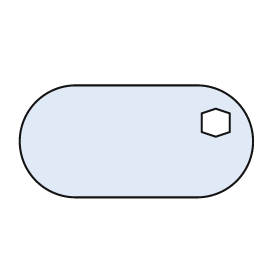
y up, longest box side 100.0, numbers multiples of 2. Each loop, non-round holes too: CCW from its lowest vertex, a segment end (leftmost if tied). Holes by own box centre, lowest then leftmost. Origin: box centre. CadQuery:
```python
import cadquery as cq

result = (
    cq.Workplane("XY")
    .moveTo(-26.0, -24.0)
    .lineTo(26.0, -24.0)
    .threePointArc((50.0, 0.0), (26.0, 24.0))
    .lineTo(-26.0, 24.0)
    .threePointArc((-50.0, 0.0), (-26.0, -24.0))
    .close()
    .moveTo(34.0, 2.0)
    .lineTo(40.0, 4.0)
    .lineTo(40.0, 12.0)
    .lineTo(34.0, 14.0)
    .lineTo(28.0, 12.0)
    .lineTo(28.0, 4.0)
    .close()
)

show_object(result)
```